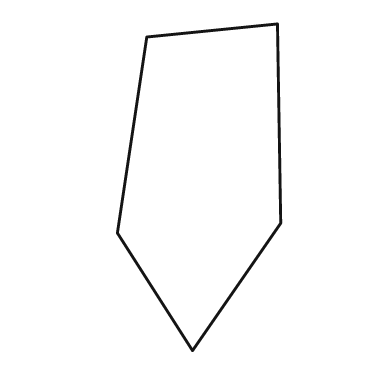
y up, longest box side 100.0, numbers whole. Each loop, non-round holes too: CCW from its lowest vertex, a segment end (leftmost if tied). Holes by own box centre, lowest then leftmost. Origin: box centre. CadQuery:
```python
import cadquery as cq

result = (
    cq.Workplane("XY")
    .moveTo(-2.0, -50.0)
    .lineTo(25.0, -11.0)
    .lineTo(24.0, 50.0)
    .lineTo(-16.0, 46.0)
    .lineTo(-25.0, -14.0)
    .close()
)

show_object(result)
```